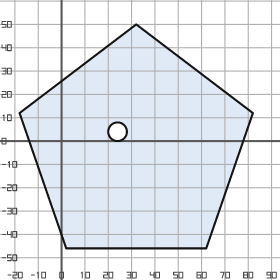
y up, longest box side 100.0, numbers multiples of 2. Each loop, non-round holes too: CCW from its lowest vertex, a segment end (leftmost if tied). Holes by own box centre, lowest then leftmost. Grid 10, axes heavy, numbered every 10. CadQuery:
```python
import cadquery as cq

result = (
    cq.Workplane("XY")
    .moveTo(2.0, -46.0)
    .lineTo(62.0, -46.0)
    .lineTo(82.0, 12.0)
    .lineTo(32.0, 50.0)
    .lineTo(-18.0, 12.0)
    .close()
    .moveTo(24.0, 4.0)
    .circle(4.0)
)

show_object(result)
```